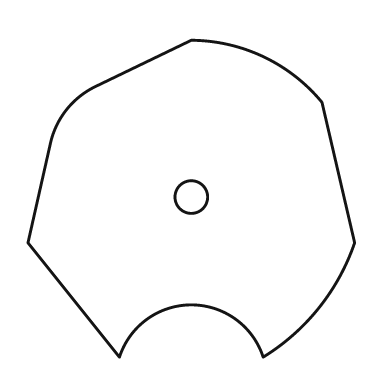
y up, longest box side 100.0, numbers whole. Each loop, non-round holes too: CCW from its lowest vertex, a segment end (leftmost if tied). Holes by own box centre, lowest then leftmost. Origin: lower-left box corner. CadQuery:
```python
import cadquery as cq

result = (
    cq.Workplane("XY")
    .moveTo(28.0, 0.0)
    .threePointArc((50.0, 16.0), (72.0, 0.0))
    .threePointArc((89.0, 15.0), (100.0, 35.0))
    .lineTo(90.0, 78.0)
    .threePointArc((72.0, 92.0), (50.0, 97.0))
    .lineTo(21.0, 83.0)
    .threePointArc((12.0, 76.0), (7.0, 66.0))
    .lineTo(0.0, 35.0)
    .close()
    .moveTo(50.0, 49.0)
    .circle(5.0)
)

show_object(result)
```